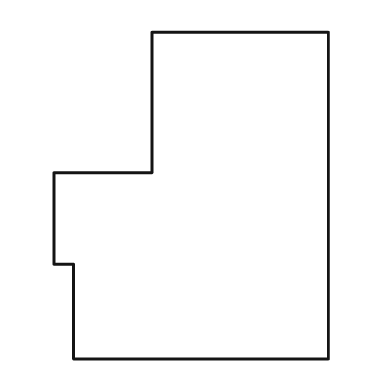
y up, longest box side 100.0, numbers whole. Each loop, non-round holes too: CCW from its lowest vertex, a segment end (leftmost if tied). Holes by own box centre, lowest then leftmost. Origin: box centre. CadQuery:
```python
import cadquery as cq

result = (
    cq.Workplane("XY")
    .moveTo(-36.0, -50.0)
    .lineTo(42.0, -50.0)
    .lineTo(42.0, 50.0)
    .lineTo(-12.0, 50.0)
    .lineTo(-12.0, 7.0)
    .lineTo(-42.0, 7.0)
    .lineTo(-42.0, -21.0)
    .lineTo(-36.0, -21.0)
    .close()
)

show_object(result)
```